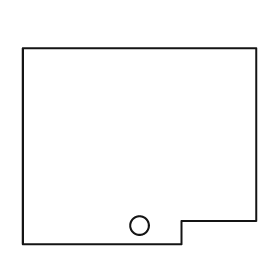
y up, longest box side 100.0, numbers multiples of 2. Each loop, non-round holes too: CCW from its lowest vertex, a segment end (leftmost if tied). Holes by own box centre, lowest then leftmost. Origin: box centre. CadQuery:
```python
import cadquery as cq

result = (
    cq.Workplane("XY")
    .moveTo(-50.0, -42.0)
    .lineTo(18.0, -42.0)
    .lineTo(18.0, -32.0)
    .lineTo(50.0, -32.0)
    .lineTo(50.0, 42.0)
    .lineTo(-50.0, 42.0)
    .close()
    .moveTo(0.0, -34.0)
    .circle(4.0)
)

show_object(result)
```